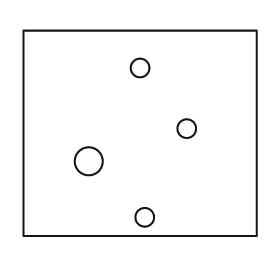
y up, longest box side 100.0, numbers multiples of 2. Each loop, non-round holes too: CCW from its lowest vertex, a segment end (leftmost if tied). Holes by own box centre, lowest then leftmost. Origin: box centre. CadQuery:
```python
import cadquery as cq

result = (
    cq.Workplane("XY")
    .moveTo(-50.0, -44.0)
    .lineTo(50.0, -44.0)
    .lineTo(50.0, 44.0)
    .lineTo(-50.0, 44.0)
    .close()
    .moveTo(2.0, -36.0)
    .circle(4.0)
    .moveTo(-22.0, -12.0)
    .circle(6.0)
    .moveTo(20.0, 2.0)
    .circle(4.0)
    .moveTo(0.0, 28.0)
    .circle(4.0)
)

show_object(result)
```